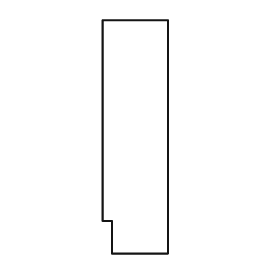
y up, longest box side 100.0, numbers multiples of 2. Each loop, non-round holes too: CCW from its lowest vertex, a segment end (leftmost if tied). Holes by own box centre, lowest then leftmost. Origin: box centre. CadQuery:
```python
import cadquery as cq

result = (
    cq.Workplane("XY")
    .moveTo(-10.0, -50.0)
    .lineTo(14.0, -50.0)
    .lineTo(14.0, 50.0)
    .lineTo(-14.0, 50.0)
    .lineTo(-14.0, -36.0)
    .lineTo(-10.0, -36.0)
    .close()
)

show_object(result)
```